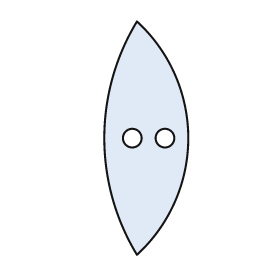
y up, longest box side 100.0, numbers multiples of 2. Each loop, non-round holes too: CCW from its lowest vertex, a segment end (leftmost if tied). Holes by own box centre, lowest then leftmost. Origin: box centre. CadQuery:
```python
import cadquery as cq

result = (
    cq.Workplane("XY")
    .moveTo(-4.0, -50.0)
    .threePointArc((18.0, 0.0), (-4.0, 50.0))
    .threePointArc((-18.0, 0.0), (-4.0, -50.0))
    .close()
    .moveTo(-6.0, 0.0)
    .circle(4.0)
    .moveTo(8.0, 0.0)
    .circle(4.0)
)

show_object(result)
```